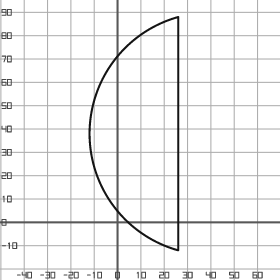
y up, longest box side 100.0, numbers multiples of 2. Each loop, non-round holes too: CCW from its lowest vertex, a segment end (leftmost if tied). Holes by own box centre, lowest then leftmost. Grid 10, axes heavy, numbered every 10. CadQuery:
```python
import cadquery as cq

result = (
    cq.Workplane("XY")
    .moveTo(26.0, -12.0)
    .lineTo(26.0, 88.0)
    .threePointArc((-12.0, 38.0), (26.0, -12.0))
    .close()
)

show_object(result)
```